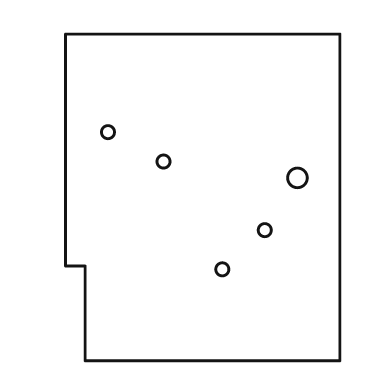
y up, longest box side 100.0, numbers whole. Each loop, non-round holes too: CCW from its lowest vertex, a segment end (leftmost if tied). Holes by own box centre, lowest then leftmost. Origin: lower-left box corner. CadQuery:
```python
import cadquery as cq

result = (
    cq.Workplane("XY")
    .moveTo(6.0, 0.0)
    .lineTo(84.0, 0.0)
    .lineTo(84.0, 100.0)
    .lineTo(0.0, 100.0)
    .lineTo(0.0, 29.0)
    .lineTo(6.0, 29.0)
    .close()
    .moveTo(48.0, 28.0)
    .circle(2.0)
    .moveTo(61.0, 40.0)
    .circle(2.0)
    .moveTo(71.0, 56.0)
    .circle(3.0)
    .moveTo(30.0, 61.0)
    .circle(2.0)
    .moveTo(13.0, 70.0)
    .circle(2.0)
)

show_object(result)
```